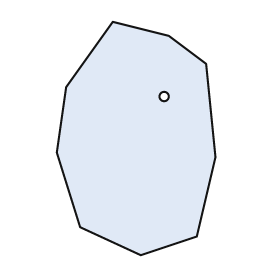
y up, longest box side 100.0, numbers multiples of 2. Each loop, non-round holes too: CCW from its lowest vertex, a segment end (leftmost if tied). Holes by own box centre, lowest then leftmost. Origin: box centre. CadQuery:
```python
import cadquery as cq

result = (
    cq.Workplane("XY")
    .moveTo(2.0, -50.0)
    .lineTo(26.0, -42.0)
    .lineTo(34.0, -8.0)
    .lineTo(30.0, 32.0)
    .lineTo(14.0, 44.0)
    .lineTo(-10.0, 50.0)
    .lineTo(-30.0, 22.0)
    .lineTo(-34.0, -6.0)
    .lineTo(-24.0, -38.0)
    .close()
    .moveTo(12.0, 18.0)
    .circle(2.0)
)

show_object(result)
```